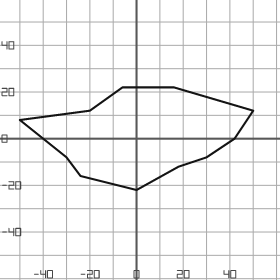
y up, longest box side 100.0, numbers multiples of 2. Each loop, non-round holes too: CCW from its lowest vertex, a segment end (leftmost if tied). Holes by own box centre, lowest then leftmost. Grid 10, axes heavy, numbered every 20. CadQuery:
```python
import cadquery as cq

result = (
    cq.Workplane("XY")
    .moveTo(0.0, -22.0)
    .lineTo(18.0, -12.0)
    .lineTo(30.0, -8.0)
    .lineTo(42.0, 0.0)
    .lineTo(50.0, 12.0)
    .lineTo(16.0, 22.0)
    .lineTo(-6.0, 22.0)
    .lineTo(-20.0, 12.0)
    .lineTo(-50.0, 8.0)
    .lineTo(-30.0, -8.0)
    .lineTo(-24.0, -16.0)
    .close()
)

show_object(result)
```